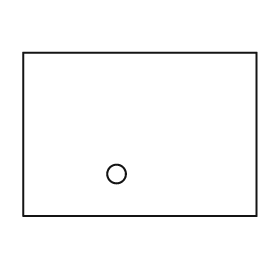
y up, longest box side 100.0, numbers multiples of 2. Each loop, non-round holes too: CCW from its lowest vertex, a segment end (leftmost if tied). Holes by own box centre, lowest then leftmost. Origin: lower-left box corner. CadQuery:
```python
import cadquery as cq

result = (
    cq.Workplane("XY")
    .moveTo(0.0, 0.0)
    .lineTo(100.0, 0.0)
    .lineTo(100.0, 70.0)
    .lineTo(0.0, 70.0)
    .close()
    .moveTo(40.0, 18.0)
    .circle(4.0)
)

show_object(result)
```